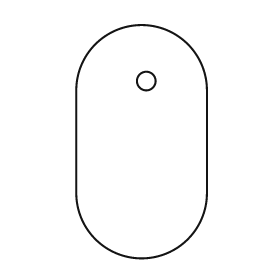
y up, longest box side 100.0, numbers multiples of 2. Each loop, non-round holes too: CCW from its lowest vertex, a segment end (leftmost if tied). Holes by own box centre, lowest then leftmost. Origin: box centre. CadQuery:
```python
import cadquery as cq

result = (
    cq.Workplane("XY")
    .moveTo(-28.0, -22.0)
    .threePointArc((0.0, -50.0), (28.0, -22.0))
    .lineTo(28.0, 22.0)
    .threePointArc((0.0, 50.0), (-28.0, 22.0))
    .close()
    .moveTo(2.0, 26.0)
    .circle(4.0)
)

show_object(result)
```